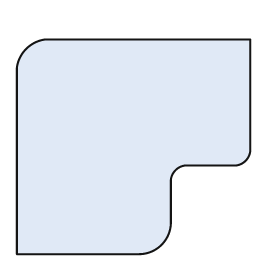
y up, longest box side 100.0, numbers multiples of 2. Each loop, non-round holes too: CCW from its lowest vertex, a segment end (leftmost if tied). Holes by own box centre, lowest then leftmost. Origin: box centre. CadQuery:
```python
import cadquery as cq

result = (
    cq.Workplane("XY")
    .moveTo(-50.0, -46.0)
    .lineTo(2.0, -46.0)
    .threePointArc((12.0, -42.0), (16.0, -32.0))
    .lineTo(16.0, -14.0)
    .threePointArc((18.0, -10.0), (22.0, -8.0))
    .lineTo(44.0, -8.0)
    .threePointArc((48.0, -6.0), (50.0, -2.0))
    .lineTo(50.0, 46.0)
    .lineTo(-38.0, 46.0)
    .threePointArc((-46.0, 42.0), (-50.0, 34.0))
    .close()
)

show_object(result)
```